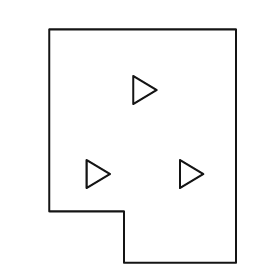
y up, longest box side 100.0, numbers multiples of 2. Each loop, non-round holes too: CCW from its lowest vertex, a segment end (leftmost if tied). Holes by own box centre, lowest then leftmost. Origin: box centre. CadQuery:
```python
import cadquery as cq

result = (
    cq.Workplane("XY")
    .moveTo(-8.0, -50.0)
    .lineTo(40.0, -50.0)
    .lineTo(40.0, 50.0)
    .lineTo(-40.0, 50.0)
    .lineTo(-40.0, -28.0)
    .lineTo(-8.0, -28.0)
    .close()
    .moveTo(-24.0, -18.0)
    .lineTo(-14.0, -12.0)
    .lineTo(-24.0, -6.0)
    .close()
    .moveTo(16.0, -18.0)
    .lineTo(26.0, -12.0)
    .lineTo(16.0, -6.0)
    .close()
    .moveTo(-4.0, 18.0)
    .lineTo(6.0, 24.0)
    .lineTo(-4.0, 30.0)
    .close()
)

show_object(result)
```